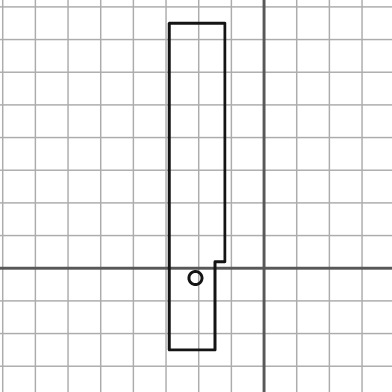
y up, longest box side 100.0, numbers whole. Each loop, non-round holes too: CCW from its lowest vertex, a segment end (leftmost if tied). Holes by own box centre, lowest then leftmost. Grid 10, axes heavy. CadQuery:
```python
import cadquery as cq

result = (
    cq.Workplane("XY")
    .moveTo(-29.0, -25.0)
    .lineTo(-15.0, -25.0)
    .lineTo(-15.0, 2.0)
    .lineTo(-12.0, 2.0)
    .lineTo(-12.0, 75.0)
    .lineTo(-29.0, 75.0)
    .close()
    .moveTo(-21.0, -3.0)
    .circle(2.0)
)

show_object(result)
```